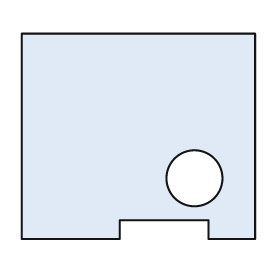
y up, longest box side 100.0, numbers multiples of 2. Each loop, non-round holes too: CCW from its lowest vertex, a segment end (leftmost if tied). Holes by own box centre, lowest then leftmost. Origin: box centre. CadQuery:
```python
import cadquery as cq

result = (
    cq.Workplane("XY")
    .moveTo(-50.0, -44.0)
    .lineTo(-8.0, -44.0)
    .lineTo(-8.0, -36.0)
    .lineTo(30.0, -36.0)
    .lineTo(30.0, -44.0)
    .lineTo(50.0, -44.0)
    .lineTo(50.0, 44.0)
    .lineTo(-50.0, 44.0)
    .close()
    .moveTo(24.0, -18.0)
    .circle(12.0)
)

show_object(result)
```